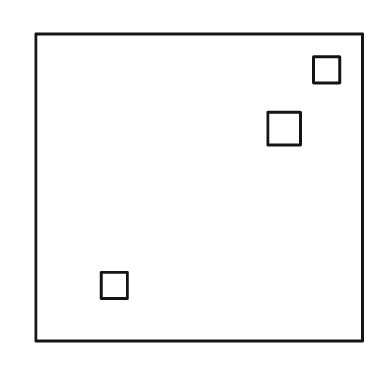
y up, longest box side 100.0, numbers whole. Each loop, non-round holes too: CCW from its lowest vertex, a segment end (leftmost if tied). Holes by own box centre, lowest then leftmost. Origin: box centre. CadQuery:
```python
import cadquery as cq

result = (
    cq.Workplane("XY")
    .moveTo(-50.0, -47.0)
    .lineTo(50.0, -47.0)
    .lineTo(50.0, 47.0)
    .lineTo(-50.0, 47.0)
    .close()
    .moveTo(-30.0, -34.0)
    .lineTo(-22.0, -34.0)
    .lineTo(-22.0, -26.0)
    .lineTo(-30.0, -26.0)
    .close()
    .moveTo(21.0, 13.0)
    .lineTo(31.0, 13.0)
    .lineTo(31.0, 23.0)
    .lineTo(21.0, 23.0)
    .close()
    .moveTo(35.0, 32.0)
    .lineTo(43.0, 32.0)
    .lineTo(43.0, 40.0)
    .lineTo(35.0, 40.0)
    .close()
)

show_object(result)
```